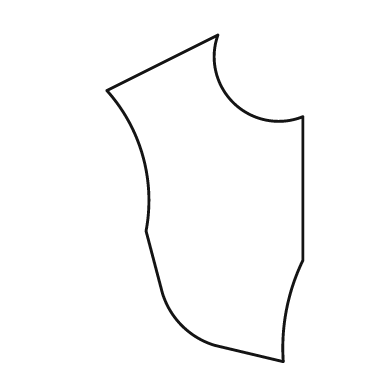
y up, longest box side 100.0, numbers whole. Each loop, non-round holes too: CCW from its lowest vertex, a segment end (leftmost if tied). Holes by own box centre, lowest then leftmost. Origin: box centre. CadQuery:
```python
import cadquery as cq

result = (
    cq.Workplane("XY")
    .moveTo(24.0, -50.0)
    .threePointArc((25.0, -34.0), (30.0, -19.0))
    .lineTo(30.0, 25.0)
    .threePointArc((9.0, 29.0), (4.0, 50.0))
    .lineTo(-30.0, 33.0)
    .threePointArc((-19.0, 13.0), (-18.0, -10.0))
    .lineTo(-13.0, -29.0)
    .threePointArc((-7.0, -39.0), (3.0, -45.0))
    .close()
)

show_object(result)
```